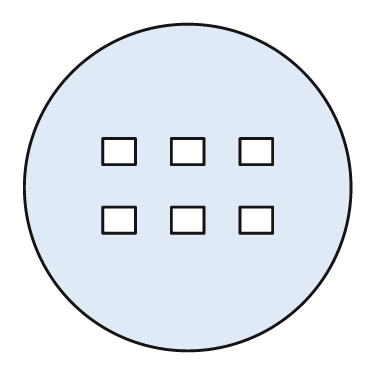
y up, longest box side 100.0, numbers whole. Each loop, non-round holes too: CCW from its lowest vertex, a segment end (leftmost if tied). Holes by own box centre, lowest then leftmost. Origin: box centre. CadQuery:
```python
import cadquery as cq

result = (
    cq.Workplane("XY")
    .moveTo(0.0, 0.0)
    .circle(50.0)
    .moveTo(-26.0, -14.0)
    .lineTo(-16.0, -14.0)
    .lineTo(-16.0, -6.0)
    .lineTo(-26.0, -6.0)
    .close()
    .moveTo(-5.0, -14.0)
    .lineTo(5.0, -14.0)
    .lineTo(5.0, -6.0)
    .lineTo(-5.0, -6.0)
    .close()
    .moveTo(16.0, -14.0)
    .lineTo(26.0, -14.0)
    .lineTo(26.0, -6.0)
    .lineTo(16.0, -6.0)
    .close()
    .moveTo(-26.0, 7.0)
    .lineTo(-16.0, 7.0)
    .lineTo(-16.0, 15.0)
    .lineTo(-26.0, 15.0)
    .close()
    .moveTo(-5.0, 7.0)
    .lineTo(5.0, 7.0)
    .lineTo(5.0, 15.0)
    .lineTo(-5.0, 15.0)
    .close()
    .moveTo(16.0, 7.0)
    .lineTo(26.0, 7.0)
    .lineTo(26.0, 15.0)
    .lineTo(16.0, 15.0)
    .close()
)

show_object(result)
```